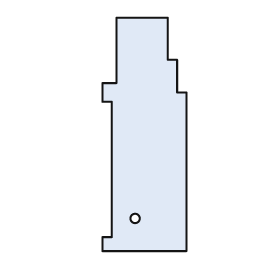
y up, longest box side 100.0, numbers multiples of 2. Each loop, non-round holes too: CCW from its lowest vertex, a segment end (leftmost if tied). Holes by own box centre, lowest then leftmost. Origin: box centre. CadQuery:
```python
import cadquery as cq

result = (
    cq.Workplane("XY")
    .moveTo(-18.0, -50.0)
    .lineTo(18.0, -50.0)
    .lineTo(18.0, 18.0)
    .lineTo(14.0, 18.0)
    .lineTo(14.0, 32.0)
    .lineTo(10.0, 32.0)
    .lineTo(10.0, 50.0)
    .lineTo(-12.0, 50.0)
    .lineTo(-12.0, 22.0)
    .lineTo(-18.0, 22.0)
    .lineTo(-18.0, 14.0)
    .lineTo(-14.0, 14.0)
    .lineTo(-14.0, -44.0)
    .lineTo(-18.0, -44.0)
    .close()
    .moveTo(-4.0, -36.0)
    .circle(2.0)
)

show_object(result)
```